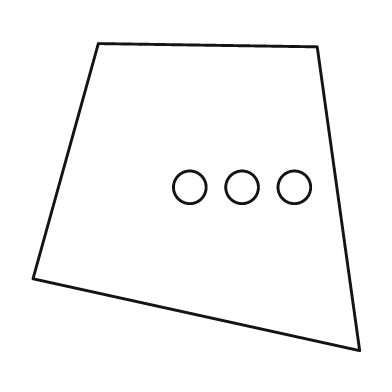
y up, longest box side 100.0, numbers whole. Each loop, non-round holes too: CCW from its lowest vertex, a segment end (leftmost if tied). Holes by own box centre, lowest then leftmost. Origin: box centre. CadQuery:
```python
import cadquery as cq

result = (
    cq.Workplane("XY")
    .moveTo(50.0, -47.0)
    .lineTo(37.0, 46.0)
    .lineTo(-30.0, 47.0)
    .lineTo(-50.0, -25.0)
    .close()
    .moveTo(-2.0, 3.0)
    .circle(5.0)
    .moveTo(14.0, 3.0)
    .circle(5.0)
    .moveTo(30.0, 3.0)
    .circle(5.0)
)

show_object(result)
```